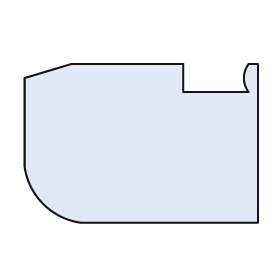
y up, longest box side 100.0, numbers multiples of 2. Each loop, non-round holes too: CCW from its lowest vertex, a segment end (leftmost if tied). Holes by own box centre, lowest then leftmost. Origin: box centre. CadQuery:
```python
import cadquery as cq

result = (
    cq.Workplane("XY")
    .moveTo(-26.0, -34.0)
    .lineTo(50.0, -34.0)
    .lineTo(50.0, 34.0)
    .lineTo(46.0, 34.0)
    .threePointArc((44.0, 28.0), (46.0, 22.0))
    .lineTo(18.0, 22.0)
    .lineTo(18.0, 34.0)
    .lineTo(-30.0, 34.0)
    .lineTo(-50.0, 28.0)
    .lineTo(-50.0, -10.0)
    .threePointArc((-42.0, -26.0), (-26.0, -34.0))
    .close()
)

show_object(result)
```